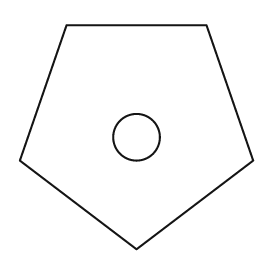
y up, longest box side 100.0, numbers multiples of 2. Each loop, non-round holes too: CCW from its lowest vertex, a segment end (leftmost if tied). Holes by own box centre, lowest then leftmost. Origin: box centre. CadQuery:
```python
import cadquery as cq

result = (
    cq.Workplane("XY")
    .moveTo(0.0, -48.0)
    .lineTo(50.0, -10.0)
    .lineTo(30.0, 48.0)
    .lineTo(-30.0, 48.0)
    .lineTo(-50.0, -10.0)
    .close()
    .moveTo(0.0, 0.0)
    .circle(10.0)
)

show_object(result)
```